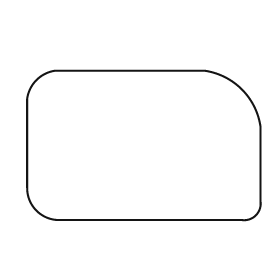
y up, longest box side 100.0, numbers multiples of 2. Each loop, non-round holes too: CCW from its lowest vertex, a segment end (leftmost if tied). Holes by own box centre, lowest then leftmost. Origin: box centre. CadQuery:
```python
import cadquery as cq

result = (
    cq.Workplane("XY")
    .moveTo(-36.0, -32.0)
    .lineTo(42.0, -32.0)
    .threePointArc((48.0, -30.0), (50.0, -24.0))
    .lineTo(50.0, 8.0)
    .threePointArc((42.0, 24.0), (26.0, 32.0))
    .lineTo(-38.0, 32.0)
    .threePointArc((-46.0, 28.0), (-50.0, 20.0))
    .lineTo(-50.0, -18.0)
    .threePointArc((-46.0, -28.0), (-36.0, -32.0))
    .close()
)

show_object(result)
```